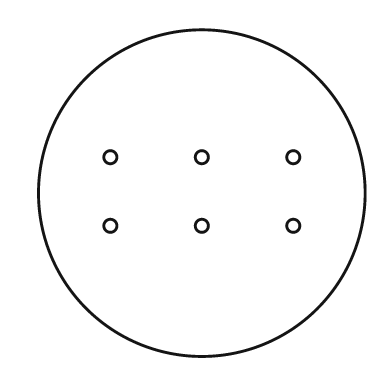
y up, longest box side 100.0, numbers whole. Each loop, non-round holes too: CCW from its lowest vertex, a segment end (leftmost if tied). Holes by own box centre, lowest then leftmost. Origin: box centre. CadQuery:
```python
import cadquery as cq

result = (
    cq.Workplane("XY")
    .moveTo(0.0, 0.0)
    .circle(50.0)
    .moveTo(-28.0, -10.0)
    .circle(2.0)
    .moveTo(0.0, -10.0)
    .circle(2.0)
    .moveTo(28.0, -10.0)
    .circle(2.0)
    .moveTo(-28.0, 11.0)
    .circle(2.0)
    .moveTo(0.0, 11.0)
    .circle(2.0)
    .moveTo(28.0, 11.0)
    .circle(2.0)
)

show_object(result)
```